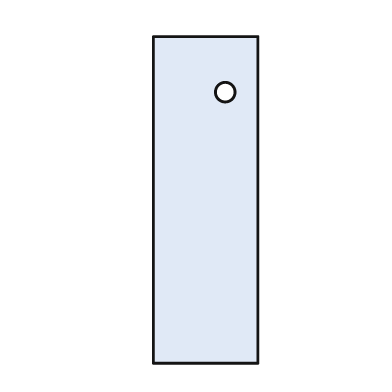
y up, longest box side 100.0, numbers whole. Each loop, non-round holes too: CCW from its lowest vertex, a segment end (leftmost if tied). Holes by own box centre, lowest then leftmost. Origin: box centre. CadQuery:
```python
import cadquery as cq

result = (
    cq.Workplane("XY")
    .moveTo(-16.0, -50.0)
    .lineTo(16.0, -50.0)
    .lineTo(16.0, 50.0)
    .lineTo(-16.0, 50.0)
    .close()
    .moveTo(6.0, 33.0)
    .circle(3.0)
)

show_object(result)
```